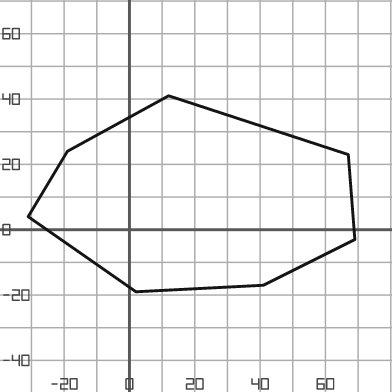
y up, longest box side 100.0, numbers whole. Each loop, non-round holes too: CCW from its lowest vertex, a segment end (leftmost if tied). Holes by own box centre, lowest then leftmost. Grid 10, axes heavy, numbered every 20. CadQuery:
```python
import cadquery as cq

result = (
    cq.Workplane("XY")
    .moveTo(2.0, -19.0)
    .lineTo(41.0, -17.0)
    .lineTo(69.0, -3.0)
    .lineTo(67.0, 23.0)
    .lineTo(12.0, 41.0)
    .lineTo(-19.0, 24.0)
    .lineTo(-31.0, 4.0)
    .close()
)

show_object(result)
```